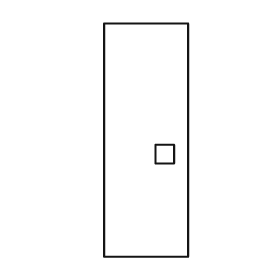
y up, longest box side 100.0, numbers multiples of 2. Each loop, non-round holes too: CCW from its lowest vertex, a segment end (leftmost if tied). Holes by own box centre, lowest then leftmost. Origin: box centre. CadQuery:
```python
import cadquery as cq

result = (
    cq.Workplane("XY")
    .moveTo(-18.0, -50.0)
    .lineTo(18.0, -50.0)
    .lineTo(18.0, 50.0)
    .lineTo(-18.0, 50.0)
    .close()
    .moveTo(4.0, -10.0)
    .lineTo(12.0, -10.0)
    .lineTo(12.0, -2.0)
    .lineTo(4.0, -2.0)
    .close()
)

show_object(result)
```